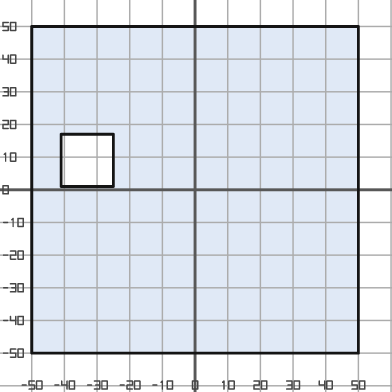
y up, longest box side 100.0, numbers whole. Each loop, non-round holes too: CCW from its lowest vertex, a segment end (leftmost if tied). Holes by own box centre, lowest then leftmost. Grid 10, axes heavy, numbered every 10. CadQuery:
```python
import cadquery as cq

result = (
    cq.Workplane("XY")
    .moveTo(-50.0, -50.0)
    .lineTo(50.0, -50.0)
    .lineTo(50.0, 50.0)
    .lineTo(-50.0, 50.0)
    .close()
    .moveTo(-41.0, 1.0)
    .lineTo(-25.0, 1.0)
    .lineTo(-25.0, 17.0)
    .lineTo(-41.0, 17.0)
    .close()
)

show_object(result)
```